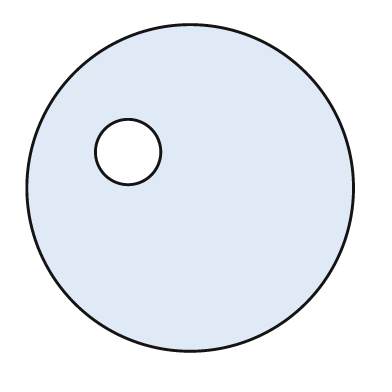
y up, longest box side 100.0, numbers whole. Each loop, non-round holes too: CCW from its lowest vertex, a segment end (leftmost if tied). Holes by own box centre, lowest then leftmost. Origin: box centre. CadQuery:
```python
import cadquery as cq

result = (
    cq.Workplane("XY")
    .moveTo(0.0, 0.0)
    .circle(50.0)
    .moveTo(-19.0, 11.0)
    .circle(10.0)
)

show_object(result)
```